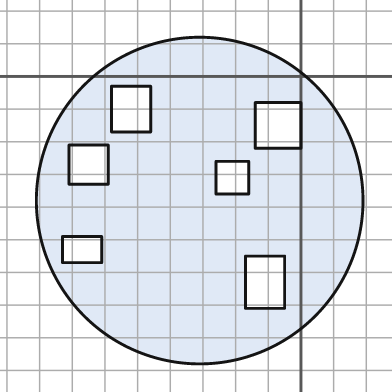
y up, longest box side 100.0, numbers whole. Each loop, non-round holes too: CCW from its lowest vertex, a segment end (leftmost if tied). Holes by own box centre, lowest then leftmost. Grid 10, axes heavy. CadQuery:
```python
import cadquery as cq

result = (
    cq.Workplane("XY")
    .moveTo(-31.0, -38.0)
    .circle(50.0)
    .moveTo(-17.0, -71.0)
    .lineTo(-5.0, -71.0)
    .lineTo(-5.0, -55.0)
    .lineTo(-17.0, -55.0)
    .close()
    .moveTo(-73.0, -57.0)
    .lineTo(-61.0, -57.0)
    .lineTo(-61.0, -49.0)
    .lineTo(-73.0, -49.0)
    .close()
    .moveTo(-26.0, -36.0)
    .lineTo(-16.0, -36.0)
    .lineTo(-16.0, -26.0)
    .lineTo(-26.0, -26.0)
    .close()
    .moveTo(-71.0, -33.0)
    .lineTo(-59.0, -33.0)
    .lineTo(-59.0, -21.0)
    .lineTo(-71.0, -21.0)
    .close()
    .moveTo(-14.0, -22.0)
    .lineTo(0.0, -22.0)
    .lineTo(0.0, -8.0)
    .lineTo(-14.0, -8.0)
    .close()
    .moveTo(-58.0, -17.0)
    .lineTo(-46.0, -17.0)
    .lineTo(-46.0, -3.0)
    .lineTo(-58.0, -3.0)
    .close()
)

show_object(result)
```